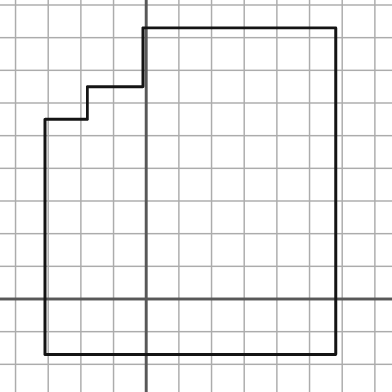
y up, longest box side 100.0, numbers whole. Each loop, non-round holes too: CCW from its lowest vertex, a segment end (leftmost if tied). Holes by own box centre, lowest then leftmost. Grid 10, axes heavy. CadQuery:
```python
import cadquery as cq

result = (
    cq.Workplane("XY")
    .moveTo(-31.0, -17.0)
    .lineTo(58.0, -17.0)
    .lineTo(58.0, 83.0)
    .lineTo(-1.0, 83.0)
    .lineTo(-1.0, 65.0)
    .lineTo(-18.0, 65.0)
    .lineTo(-18.0, 55.0)
    .lineTo(-31.0, 55.0)
    .close()
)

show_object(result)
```